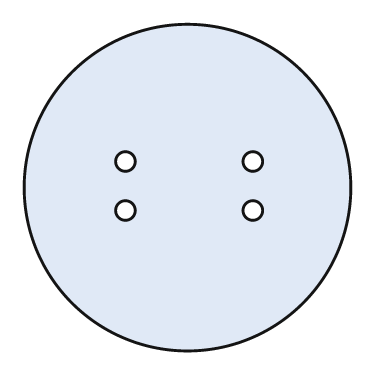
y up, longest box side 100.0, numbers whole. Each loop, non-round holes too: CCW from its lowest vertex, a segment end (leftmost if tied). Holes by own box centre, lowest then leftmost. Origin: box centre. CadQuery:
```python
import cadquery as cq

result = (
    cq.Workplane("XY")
    .moveTo(0.0, 0.0)
    .circle(50.0)
    .moveTo(-19.0, -7.0)
    .circle(3.0)
    .moveTo(20.0, -7.0)
    .circle(3.0)
    .moveTo(-19.0, 8.0)
    .circle(3.0)
    .moveTo(20.0, 8.0)
    .circle(3.0)
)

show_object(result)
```